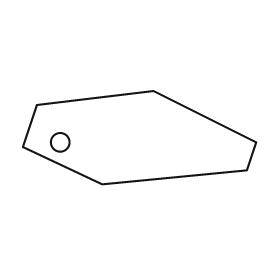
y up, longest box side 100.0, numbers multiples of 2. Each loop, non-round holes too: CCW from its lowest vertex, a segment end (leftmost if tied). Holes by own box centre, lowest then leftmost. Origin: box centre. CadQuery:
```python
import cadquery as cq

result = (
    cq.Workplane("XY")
    .moveTo(-16.0, -20.0)
    .lineTo(46.0, -14.0)
    .lineTo(50.0, -2.0)
    .lineTo(6.0, 20.0)
    .lineTo(-44.0, 14.0)
    .lineTo(-50.0, -4.0)
    .close()
    .moveTo(-34.0, -2.0)
    .circle(4.0)
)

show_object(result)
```